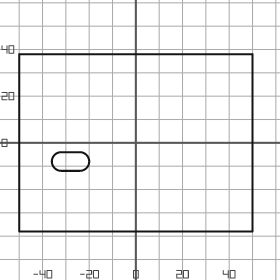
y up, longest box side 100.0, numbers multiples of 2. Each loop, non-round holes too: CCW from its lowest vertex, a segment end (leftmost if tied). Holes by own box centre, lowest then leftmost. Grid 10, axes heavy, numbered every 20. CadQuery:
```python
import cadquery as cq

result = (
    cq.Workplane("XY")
    .moveTo(-50.0, -38.0)
    .lineTo(50.0, -38.0)
    .lineTo(50.0, 38.0)
    .lineTo(-50.0, 38.0)
    .close()
    .moveTo(-32.0, -12.0)
    .lineTo(-24.0, -12.0)
    .threePointArc((-20.0, -8.0), (-24.0, -4.0))
    .lineTo(-32.0, -4.0)
    .threePointArc((-36.0, -8.0), (-32.0, -12.0))
    .close()
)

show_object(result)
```